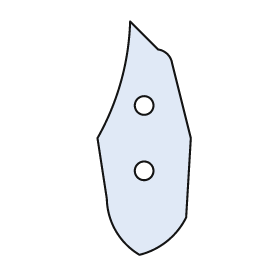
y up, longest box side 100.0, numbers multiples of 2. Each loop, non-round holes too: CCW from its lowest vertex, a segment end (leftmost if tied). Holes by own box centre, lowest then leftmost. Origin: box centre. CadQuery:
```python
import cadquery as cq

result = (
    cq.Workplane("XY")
    .moveTo(-2.0, -50.0)
    .threePointArc((10.0, -44.0), (18.0, -34.0))
    .lineTo(20.0, 0.0)
    .lineTo(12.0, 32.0)
    .threePointArc((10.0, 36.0), (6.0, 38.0))
    .lineTo(-6.0, 50.0)
    .threePointArc((-10.0, 24.0), (-20.0, 0.0))
    .lineTo(-16.0, -26.0)
    .threePointArc((-12.0, -40.0), (-2.0, -50.0))
    .close()
    .moveTo(0.0, -14.0)
    .circle(4.0)
    .moveTo(0.0, 14.0)
    .circle(4.0)
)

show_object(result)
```